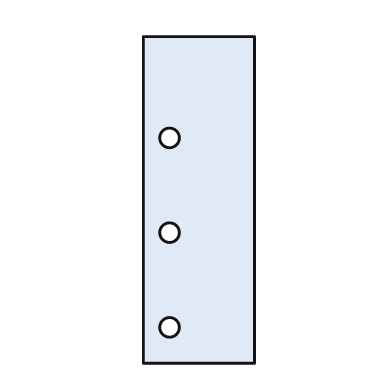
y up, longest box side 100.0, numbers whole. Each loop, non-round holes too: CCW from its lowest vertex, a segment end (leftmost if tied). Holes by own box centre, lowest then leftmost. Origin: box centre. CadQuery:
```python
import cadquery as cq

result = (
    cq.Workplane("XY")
    .moveTo(-17.0, -50.0)
    .lineTo(17.0, -50.0)
    .lineTo(17.0, 50.0)
    .lineTo(-17.0, 50.0)
    .close()
    .moveTo(-9.0, -39.0)
    .circle(3.0)
    .moveTo(-9.0, -10.0)
    .circle(3.0)
    .moveTo(-9.0, 19.0)
    .circle(3.0)
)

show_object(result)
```